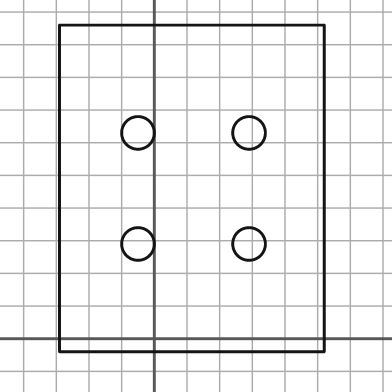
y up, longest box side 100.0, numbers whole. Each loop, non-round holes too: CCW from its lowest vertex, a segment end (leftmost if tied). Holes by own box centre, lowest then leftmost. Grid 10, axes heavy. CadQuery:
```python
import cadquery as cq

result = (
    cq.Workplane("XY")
    .moveTo(-29.0, -4.0)
    .lineTo(52.0, -4.0)
    .lineTo(52.0, 96.0)
    .lineTo(-29.0, 96.0)
    .close()
    .moveTo(-5.0, 29.0)
    .circle(5.0)
    .moveTo(29.0, 29.0)
    .circle(5.0)
    .moveTo(-5.0, 63.0)
    .circle(5.0)
    .moveTo(29.0, 63.0)
    .circle(5.0)
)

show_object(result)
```